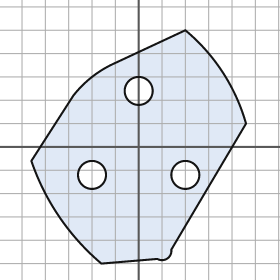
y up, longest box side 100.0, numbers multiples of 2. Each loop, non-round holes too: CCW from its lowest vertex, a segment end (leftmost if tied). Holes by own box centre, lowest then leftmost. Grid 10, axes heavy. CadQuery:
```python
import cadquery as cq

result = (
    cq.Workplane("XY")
    .moveTo(-16.0, -50.0)
    .lineTo(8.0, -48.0)
    .threePointArc((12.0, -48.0), (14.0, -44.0))
    .lineTo(46.0, 10.0)
    .threePointArc((36.0, 32.0), (20.0, 50.0))
    .lineTo(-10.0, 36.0)
    .threePointArc((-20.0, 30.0), (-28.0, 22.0))
    .lineTo(-46.0, -6.0)
    .threePointArc((-34.0, -30.0), (-16.0, -50.0))
    .close()
    .moveTo(-20.0, -12.0)
    .circle(6.0)
    .moveTo(20.0, -12.0)
    .circle(6.0)
    .moveTo(0.0, 24.0)
    .circle(6.0)
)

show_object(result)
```